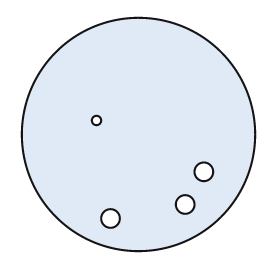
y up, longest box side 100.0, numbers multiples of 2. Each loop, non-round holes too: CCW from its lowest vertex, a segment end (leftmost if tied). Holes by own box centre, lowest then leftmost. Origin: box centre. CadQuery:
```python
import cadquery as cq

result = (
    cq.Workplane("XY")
    .moveTo(0.0, 0.0)
    .circle(50.0)
    .moveTo(-12.0, -36.0)
    .circle(4.0)
    .moveTo(20.0, -30.0)
    .circle(4.0)
    .moveTo(28.0, -16.0)
    .circle(4.0)
    .moveTo(-18.0, 6.0)
    .circle(2.0)
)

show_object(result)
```